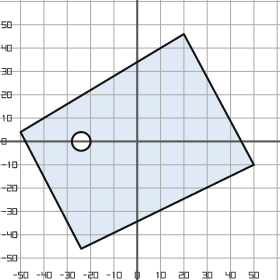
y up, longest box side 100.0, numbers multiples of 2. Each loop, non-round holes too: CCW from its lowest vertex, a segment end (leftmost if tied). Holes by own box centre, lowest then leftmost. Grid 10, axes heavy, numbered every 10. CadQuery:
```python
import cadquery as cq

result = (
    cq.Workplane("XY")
    .moveTo(-24.0, -46.0)
    .lineTo(50.0, -10.0)
    .lineTo(20.0, 46.0)
    .lineTo(-50.0, 4.0)
    .close()
    .moveTo(-24.0, 0.0)
    .circle(4.0)
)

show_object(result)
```